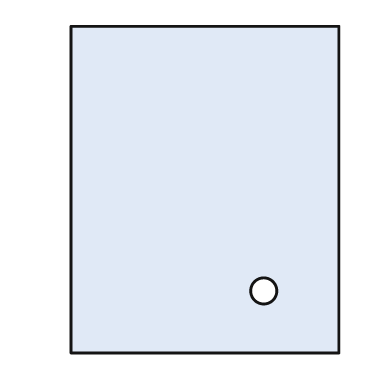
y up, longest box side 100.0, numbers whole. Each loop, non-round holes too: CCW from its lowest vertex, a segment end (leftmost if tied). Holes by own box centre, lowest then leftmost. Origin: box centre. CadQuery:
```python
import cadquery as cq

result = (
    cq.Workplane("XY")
    .moveTo(-41.0, -50.0)
    .lineTo(41.0, -50.0)
    .lineTo(41.0, 50.0)
    .lineTo(-41.0, 50.0)
    .close()
    .moveTo(18.0, -31.0)
    .circle(4.0)
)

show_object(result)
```